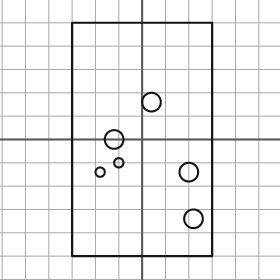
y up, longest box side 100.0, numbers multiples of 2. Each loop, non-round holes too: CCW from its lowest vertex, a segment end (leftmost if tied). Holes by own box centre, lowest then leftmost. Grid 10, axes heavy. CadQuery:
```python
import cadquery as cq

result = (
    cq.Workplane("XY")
    .moveTo(-30.0, -50.0)
    .lineTo(30.0, -50.0)
    .lineTo(30.0, 50.0)
    .lineTo(-30.0, 50.0)
    .close()
    .moveTo(22.0, -34.0)
    .circle(4.0)
    .moveTo(-18.0, -14.0)
    .circle(2.0)
    .moveTo(20.0, -14.0)
    .circle(4.0)
    .moveTo(-10.0, -10.0)
    .circle(2.0)
    .moveTo(-12.0, 0.0)
    .circle(4.0)
    .moveTo(4.0, 16.0)
    .circle(4.0)
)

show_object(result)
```